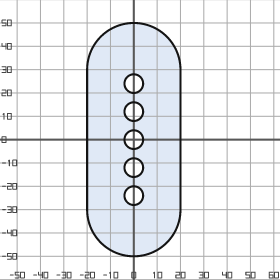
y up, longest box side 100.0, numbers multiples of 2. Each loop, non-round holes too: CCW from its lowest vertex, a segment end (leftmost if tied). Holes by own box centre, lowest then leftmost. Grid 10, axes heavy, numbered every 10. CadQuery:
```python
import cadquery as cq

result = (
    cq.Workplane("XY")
    .moveTo(-20.0, -30.0)
    .threePointArc((0.0, -50.0), (20.0, -30.0))
    .lineTo(20.0, 30.0)
    .threePointArc((0.0, 50.0), (-20.0, 30.0))
    .close()
    .moveTo(0.0, -24.0)
    .circle(4.0)
    .moveTo(0.0, -12.0)
    .circle(4.0)
    .moveTo(0.0, 0.0)
    .circle(4.0)
    .moveTo(0.0, 12.0)
    .circle(4.0)
    .moveTo(0.0, 24.0)
    .circle(4.0)
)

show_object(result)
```